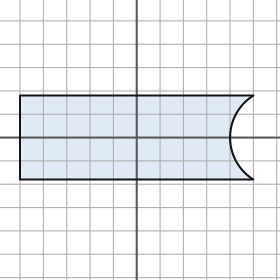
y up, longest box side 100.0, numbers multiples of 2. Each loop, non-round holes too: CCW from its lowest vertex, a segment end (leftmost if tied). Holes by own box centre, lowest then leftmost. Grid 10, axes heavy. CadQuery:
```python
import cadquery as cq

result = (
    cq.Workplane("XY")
    .moveTo(-50.0, -18.0)
    .lineTo(50.0, -18.0)
    .threePointArc((40.0, 0.0), (50.0, 18.0))
    .lineTo(-50.0, 18.0)
    .close()
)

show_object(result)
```